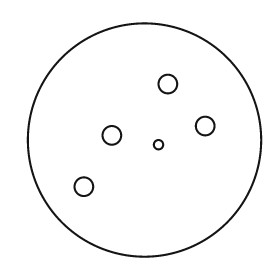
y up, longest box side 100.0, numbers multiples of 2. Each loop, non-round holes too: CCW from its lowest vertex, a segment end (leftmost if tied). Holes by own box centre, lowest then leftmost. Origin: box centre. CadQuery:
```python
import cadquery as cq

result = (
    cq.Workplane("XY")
    .moveTo(0.0, 0.0)
    .circle(50.0)
    .moveTo(-26.0, -20.0)
    .circle(4.0)
    .moveTo(6.0, -2.0)
    .circle(2.0)
    .moveTo(-14.0, 2.0)
    .circle(4.0)
    .moveTo(26.0, 6.0)
    .circle(4.0)
    .moveTo(10.0, 24.0)
    .circle(4.0)
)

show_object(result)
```